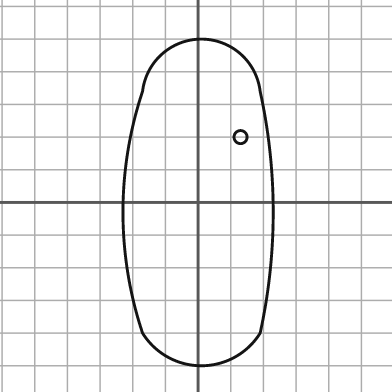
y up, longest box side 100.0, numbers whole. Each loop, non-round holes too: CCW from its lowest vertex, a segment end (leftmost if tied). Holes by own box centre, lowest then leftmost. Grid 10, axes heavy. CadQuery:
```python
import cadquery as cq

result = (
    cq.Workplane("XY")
    .moveTo(-17.0, -40.0)
    .threePointArc((1.0, -50.0), (19.0, -40.0))
    .threePointArc((23.0, -3.0), (19.0, 34.0))
    .threePointArc((1.0, 50.0), (-17.0, 34.0))
    .threePointArc((-23.0, -3.0), (-17.0, -40.0))
    .close()
    .moveTo(13.0, 20.0)
    .circle(2.0)
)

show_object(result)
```